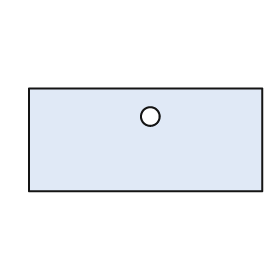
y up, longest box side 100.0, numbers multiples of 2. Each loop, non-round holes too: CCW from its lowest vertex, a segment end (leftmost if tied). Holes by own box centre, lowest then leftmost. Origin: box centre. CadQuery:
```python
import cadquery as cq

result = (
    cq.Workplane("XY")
    .moveTo(-50.0, -22.0)
    .lineTo(50.0, -22.0)
    .lineTo(50.0, 22.0)
    .lineTo(-50.0, 22.0)
    .close()
    .moveTo(2.0, 10.0)
    .circle(4.0)
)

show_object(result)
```